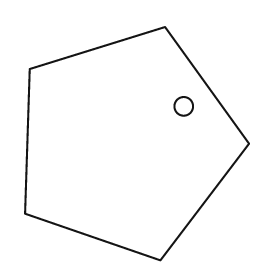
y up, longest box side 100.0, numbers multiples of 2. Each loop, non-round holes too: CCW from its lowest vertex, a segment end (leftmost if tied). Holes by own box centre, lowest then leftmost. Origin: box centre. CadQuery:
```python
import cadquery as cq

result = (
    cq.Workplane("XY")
    .moveTo(10.0, -50.0)
    .lineTo(48.0, 0.0)
    .lineTo(12.0, 50.0)
    .lineTo(-46.0, 32.0)
    .lineTo(-48.0, -30.0)
    .close()
    .moveTo(20.0, 16.0)
    .circle(4.0)
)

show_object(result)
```